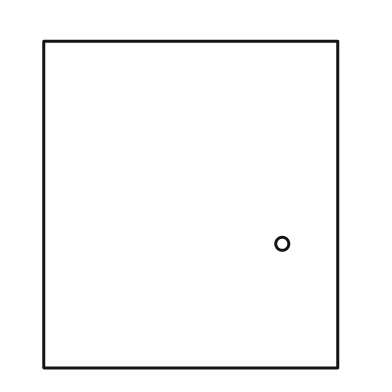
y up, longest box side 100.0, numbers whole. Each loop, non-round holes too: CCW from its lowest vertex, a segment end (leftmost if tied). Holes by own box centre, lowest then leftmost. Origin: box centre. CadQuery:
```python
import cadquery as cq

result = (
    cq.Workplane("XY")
    .moveTo(-45.0, -50.0)
    .lineTo(45.0, -50.0)
    .lineTo(45.0, 50.0)
    .lineTo(-45.0, 50.0)
    .close()
    .moveTo(28.0, -12.0)
    .circle(2.0)
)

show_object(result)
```